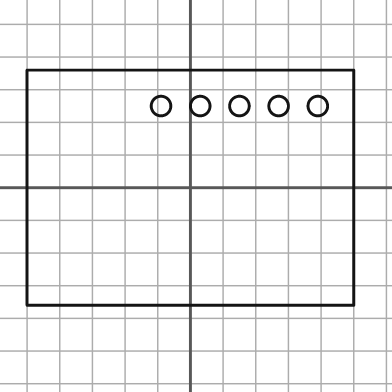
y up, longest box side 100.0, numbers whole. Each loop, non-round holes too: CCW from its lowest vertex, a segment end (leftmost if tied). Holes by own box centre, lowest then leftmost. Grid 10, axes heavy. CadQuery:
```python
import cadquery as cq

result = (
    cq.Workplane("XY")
    .moveTo(-50.0, -36.0)
    .lineTo(50.0, -36.0)
    .lineTo(50.0, 36.0)
    .lineTo(-50.0, 36.0)
    .close()
    .moveTo(-9.0, 25.0)
    .circle(3.0)
    .moveTo(3.0, 25.0)
    .circle(3.0)
    .moveTo(15.0, 25.0)
    .circle(3.0)
    .moveTo(27.0, 25.0)
    .circle(3.0)
    .moveTo(39.0, 25.0)
    .circle(3.0)
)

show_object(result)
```